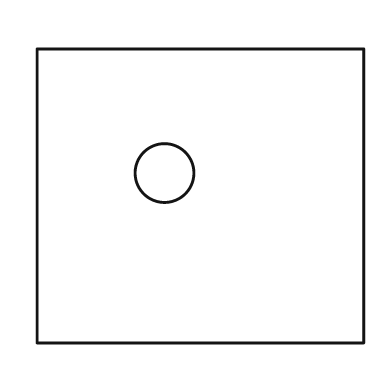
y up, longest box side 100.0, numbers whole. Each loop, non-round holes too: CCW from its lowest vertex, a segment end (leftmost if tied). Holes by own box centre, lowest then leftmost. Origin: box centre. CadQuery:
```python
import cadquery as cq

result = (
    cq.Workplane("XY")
    .moveTo(-50.0, -45.0)
    .lineTo(50.0, -45.0)
    .lineTo(50.0, 45.0)
    .lineTo(-50.0, 45.0)
    .close()
    .moveTo(-11.0, 7.0)
    .circle(9.0)
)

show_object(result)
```